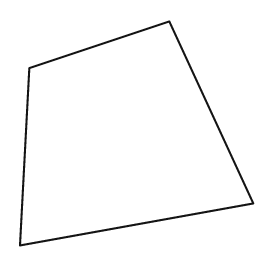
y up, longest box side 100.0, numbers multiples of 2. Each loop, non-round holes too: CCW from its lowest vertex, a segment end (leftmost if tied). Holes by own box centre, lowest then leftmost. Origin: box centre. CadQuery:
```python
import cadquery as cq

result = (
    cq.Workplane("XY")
    .moveTo(-50.0, -48.0)
    .lineTo(50.0, -30.0)
    .lineTo(14.0, 48.0)
    .lineTo(-46.0, 28.0)
    .close()
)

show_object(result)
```